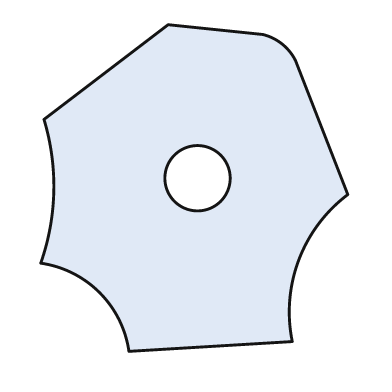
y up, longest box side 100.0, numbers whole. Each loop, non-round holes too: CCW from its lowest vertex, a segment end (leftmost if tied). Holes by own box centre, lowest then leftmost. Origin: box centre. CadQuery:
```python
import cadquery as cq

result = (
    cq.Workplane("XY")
    .moveTo(-20.0, -50.0)
    .lineTo(30.0, -47.0)
    .threePointArc((32.0, -22.0), (47.0, -2.0))
    .lineTo(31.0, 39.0)
    .threePointArc((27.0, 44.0), (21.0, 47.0))
    .lineTo(-8.0, 50.0)
    .lineTo(-46.0, 21.0)
    .threePointArc((-43.0, -1.0), (-47.0, -23.0))
    .threePointArc((-29.0, -32.0), (-20.0, -50.0))
    .close()
    .moveTo(1.0, 3.0)
    .circle(10.0)
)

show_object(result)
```